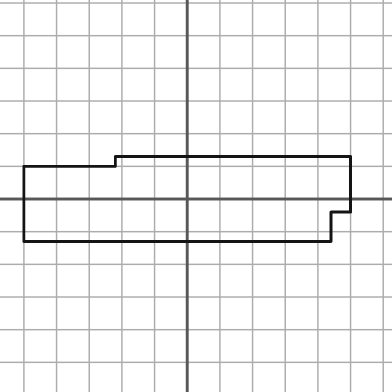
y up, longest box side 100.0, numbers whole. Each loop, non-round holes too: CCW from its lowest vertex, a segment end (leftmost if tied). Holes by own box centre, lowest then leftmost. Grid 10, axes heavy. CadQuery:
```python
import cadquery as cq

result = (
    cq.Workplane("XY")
    .moveTo(-50.0, -13.0)
    .lineTo(44.0, -13.0)
    .lineTo(44.0, -4.0)
    .lineTo(50.0, -4.0)
    .lineTo(50.0, 13.0)
    .lineTo(-22.0, 13.0)
    .lineTo(-22.0, 10.0)
    .lineTo(-50.0, 10.0)
    .close()
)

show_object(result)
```